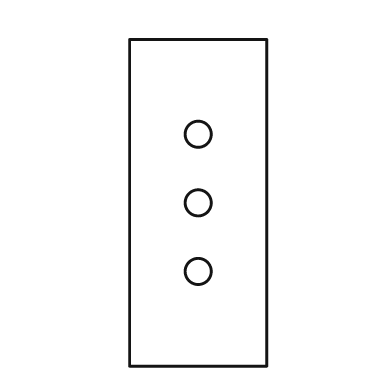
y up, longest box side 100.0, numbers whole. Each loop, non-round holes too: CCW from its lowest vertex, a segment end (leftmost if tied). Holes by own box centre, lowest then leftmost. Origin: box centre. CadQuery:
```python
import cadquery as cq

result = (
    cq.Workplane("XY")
    .moveTo(-21.0, -50.0)
    .lineTo(21.0, -50.0)
    .lineTo(21.0, 50.0)
    .lineTo(-21.0, 50.0)
    .close()
    .moveTo(0.0, -21.0)
    .circle(4.0)
    .moveTo(0.0, 0.0)
    .circle(4.0)
    .moveTo(0.0, 21.0)
    .circle(4.0)
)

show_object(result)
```